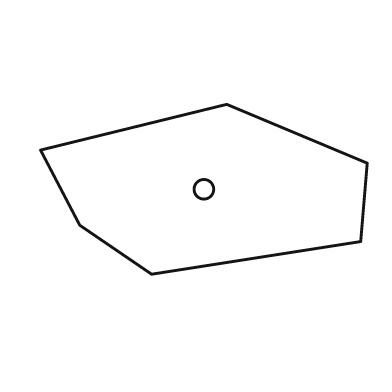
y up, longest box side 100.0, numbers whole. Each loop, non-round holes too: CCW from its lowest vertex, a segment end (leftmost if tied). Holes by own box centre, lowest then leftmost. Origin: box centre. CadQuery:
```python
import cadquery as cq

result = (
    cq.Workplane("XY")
    .moveTo(-16.0, -26.0)
    .lineTo(48.0, -16.0)
    .lineTo(50.0, 8.0)
    .lineTo(7.0, 26.0)
    .lineTo(-50.0, 12.0)
    .lineTo(-38.0, -11.0)
    .close()
    .moveTo(0.0, 0.0)
    .circle(3.0)
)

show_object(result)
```